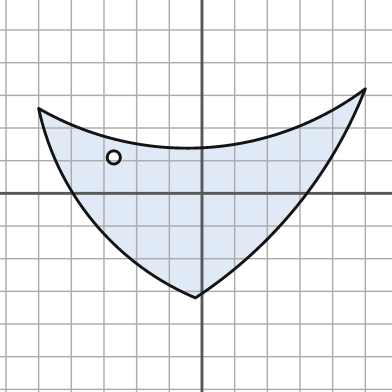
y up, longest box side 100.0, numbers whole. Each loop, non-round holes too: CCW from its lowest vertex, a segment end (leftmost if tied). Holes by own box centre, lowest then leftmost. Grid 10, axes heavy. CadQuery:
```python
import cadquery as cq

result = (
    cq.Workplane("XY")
    .moveTo(-2.0, -32.0)
    .threePointArc((29.0, -4.0), (50.0, 32.0))
    .threePointArc((1.0, 14.0), (-50.0, 26.0))
    .threePointArc((-33.0, -9.0), (-2.0, -32.0))
    .close()
    .moveTo(-27.0, 11.0)
    .circle(2.0)
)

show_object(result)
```